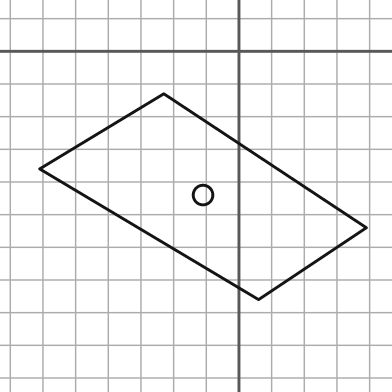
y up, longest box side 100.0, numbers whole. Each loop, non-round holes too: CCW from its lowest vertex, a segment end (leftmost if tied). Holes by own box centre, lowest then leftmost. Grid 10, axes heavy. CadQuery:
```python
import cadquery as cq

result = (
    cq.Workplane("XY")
    .moveTo(6.0, -76.0)
    .lineTo(39.0, -54.0)
    .lineTo(-23.0, -13.0)
    .lineTo(-61.0, -36.0)
    .close()
    .moveTo(-11.0, -44.0)
    .circle(3.0)
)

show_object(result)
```